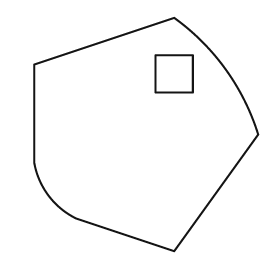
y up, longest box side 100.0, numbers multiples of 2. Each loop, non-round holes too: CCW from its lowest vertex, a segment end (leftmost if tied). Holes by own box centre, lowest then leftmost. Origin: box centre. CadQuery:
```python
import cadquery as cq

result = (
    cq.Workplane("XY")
    .moveTo(12.0, -50.0)
    .lineTo(48.0, 0.0)
    .threePointArc((34.0, 28.0), (12.0, 50.0))
    .lineTo(-48.0, 30.0)
    .lineTo(-48.0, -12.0)
    .threePointArc((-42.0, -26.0), (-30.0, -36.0))
    .close()
    .moveTo(4.0, 18.0)
    .lineTo(20.0, 18.0)
    .lineTo(20.0, 34.0)
    .lineTo(4.0, 34.0)
    .close()
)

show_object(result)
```